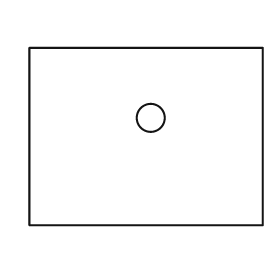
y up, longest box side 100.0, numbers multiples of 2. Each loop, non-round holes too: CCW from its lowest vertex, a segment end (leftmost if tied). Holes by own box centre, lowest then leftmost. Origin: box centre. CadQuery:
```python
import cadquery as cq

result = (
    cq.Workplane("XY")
    .moveTo(-50.0, -38.0)
    .lineTo(50.0, -38.0)
    .lineTo(50.0, 38.0)
    .lineTo(-50.0, 38.0)
    .close()
    .moveTo(2.0, 8.0)
    .circle(6.0)
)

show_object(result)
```